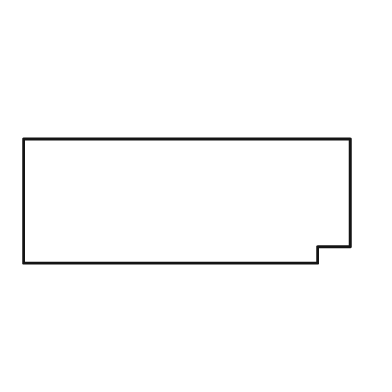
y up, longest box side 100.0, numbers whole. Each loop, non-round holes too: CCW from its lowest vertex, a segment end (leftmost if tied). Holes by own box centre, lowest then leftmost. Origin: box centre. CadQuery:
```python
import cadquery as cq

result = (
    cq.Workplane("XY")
    .moveTo(-50.0, -19.0)
    .lineTo(40.0, -19.0)
    .lineTo(40.0, -14.0)
    .lineTo(50.0, -14.0)
    .lineTo(50.0, 19.0)
    .lineTo(-50.0, 19.0)
    .close()
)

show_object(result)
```